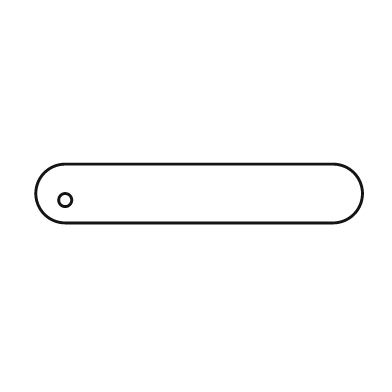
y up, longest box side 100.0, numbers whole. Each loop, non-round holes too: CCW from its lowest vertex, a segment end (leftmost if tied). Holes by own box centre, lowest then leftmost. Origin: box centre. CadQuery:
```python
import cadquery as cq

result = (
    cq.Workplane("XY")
    .moveTo(-41.0, -9.0)
    .lineTo(41.0, -9.0)
    .threePointArc((50.0, 0.0), (41.0, 9.0))
    .lineTo(-41.0, 9.0)
    .threePointArc((-50.0, 0.0), (-41.0, -9.0))
    .close()
    .moveTo(-41.0, -2.0)
    .circle(2.0)
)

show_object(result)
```